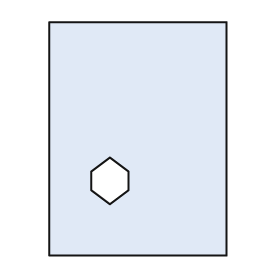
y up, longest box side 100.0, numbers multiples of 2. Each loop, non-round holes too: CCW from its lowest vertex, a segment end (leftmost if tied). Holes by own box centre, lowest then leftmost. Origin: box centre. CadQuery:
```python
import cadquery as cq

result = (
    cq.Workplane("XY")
    .moveTo(-38.0, -50.0)
    .lineTo(38.0, -50.0)
    .lineTo(38.0, 50.0)
    .lineTo(-38.0, 50.0)
    .close()
    .moveTo(-12.0, -28.0)
    .lineTo(-4.0, -22.0)
    .lineTo(-4.0, -14.0)
    .lineTo(-12.0, -8.0)
    .lineTo(-20.0, -14.0)
    .lineTo(-20.0, -22.0)
    .close()
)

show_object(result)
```